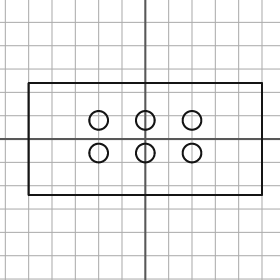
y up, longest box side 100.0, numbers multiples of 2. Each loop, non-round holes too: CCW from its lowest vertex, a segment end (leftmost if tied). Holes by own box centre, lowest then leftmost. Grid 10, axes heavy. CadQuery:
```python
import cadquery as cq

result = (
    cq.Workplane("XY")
    .moveTo(-50.0, -24.0)
    .lineTo(50.0, -24.0)
    .lineTo(50.0, 24.0)
    .lineTo(-50.0, 24.0)
    .close()
    .moveTo(-20.0, -6.0)
    .circle(4.0)
    .moveTo(0.0, -6.0)
    .circle(4.0)
    .moveTo(20.0, -6.0)
    .circle(4.0)
    .moveTo(-20.0, 8.0)
    .circle(4.0)
    .moveTo(0.0, 8.0)
    .circle(4.0)
    .moveTo(20.0, 8.0)
    .circle(4.0)
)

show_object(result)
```